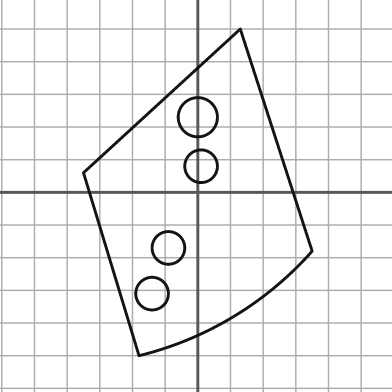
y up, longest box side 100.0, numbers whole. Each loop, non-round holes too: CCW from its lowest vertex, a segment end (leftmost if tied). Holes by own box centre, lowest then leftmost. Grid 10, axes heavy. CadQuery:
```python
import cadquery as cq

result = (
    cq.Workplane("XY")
    .moveTo(-18.0, -50.0)
    .threePointArc((11.0, -38.0), (35.0, -18.0))
    .lineTo(13.0, 50.0)
    .lineTo(-35.0, 6.0)
    .close()
    .moveTo(-14.0, -31.0)
    .circle(5.0)
    .moveTo(-9.0, -17.0)
    .circle(5.0)
    .moveTo(1.0, 8.0)
    .circle(5.0)
    .moveTo(0.0, 23.0)
    .circle(6.0)
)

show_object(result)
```